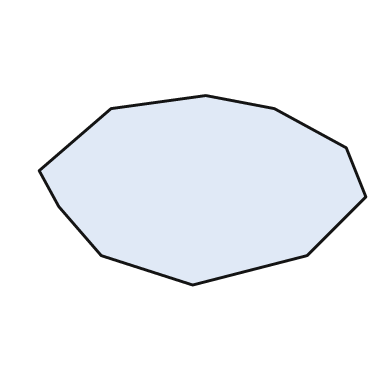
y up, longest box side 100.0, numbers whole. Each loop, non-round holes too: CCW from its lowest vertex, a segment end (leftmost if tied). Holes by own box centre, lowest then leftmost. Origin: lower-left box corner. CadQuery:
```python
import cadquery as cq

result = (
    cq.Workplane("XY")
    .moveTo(47.0, 0.0)
    .lineTo(82.0, 9.0)
    .lineTo(100.0, 27.0)
    .lineTo(94.0, 42.0)
    .lineTo(72.0, 54.0)
    .lineTo(51.0, 58.0)
    .lineTo(22.0, 54.0)
    .lineTo(0.0, 35.0)
    .lineTo(6.0, 24.0)
    .lineTo(19.0, 9.0)
    .close()
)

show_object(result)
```